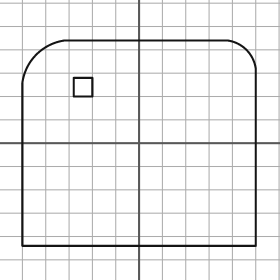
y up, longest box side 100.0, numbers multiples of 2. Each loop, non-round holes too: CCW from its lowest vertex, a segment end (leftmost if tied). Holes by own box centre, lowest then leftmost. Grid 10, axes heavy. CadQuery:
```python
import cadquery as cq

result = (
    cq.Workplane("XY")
    .moveTo(-50.0, -44.0)
    .lineTo(50.0, -44.0)
    .lineTo(50.0, 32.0)
    .threePointArc((46.0, 40.0), (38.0, 44.0))
    .lineTo(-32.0, 44.0)
    .threePointArc((-44.0, 38.0), (-50.0, 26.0))
    .close()
    .moveTo(-28.0, 20.0)
    .lineTo(-20.0, 20.0)
    .lineTo(-20.0, 28.0)
    .lineTo(-28.0, 28.0)
    .close()
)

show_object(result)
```